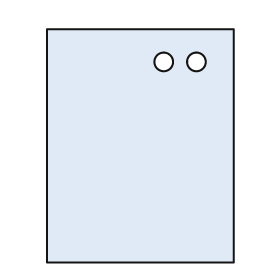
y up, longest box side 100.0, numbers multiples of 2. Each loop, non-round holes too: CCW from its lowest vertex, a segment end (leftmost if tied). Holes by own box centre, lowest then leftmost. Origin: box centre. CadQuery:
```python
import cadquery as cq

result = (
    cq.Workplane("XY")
    .moveTo(-40.0, -50.0)
    .lineTo(40.0, -50.0)
    .lineTo(40.0, 50.0)
    .lineTo(-40.0, 50.0)
    .close()
    .moveTo(10.0, 36.0)
    .circle(4.0)
    .moveTo(24.0, 36.0)
    .circle(4.0)
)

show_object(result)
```